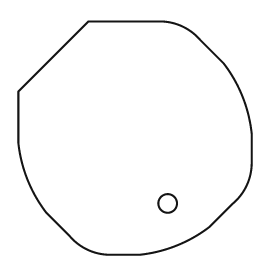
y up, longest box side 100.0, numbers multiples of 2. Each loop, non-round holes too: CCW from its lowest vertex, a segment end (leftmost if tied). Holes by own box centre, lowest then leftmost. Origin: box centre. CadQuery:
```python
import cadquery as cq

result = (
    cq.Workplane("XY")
    .moveTo(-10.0, -50.0)
    .lineTo(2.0, -50.0)
    .threePointArc((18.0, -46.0), (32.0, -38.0))
    .lineTo(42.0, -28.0)
    .threePointArc((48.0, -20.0), (50.0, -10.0))
    .lineTo(50.0, 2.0)
    .threePointArc((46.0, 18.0), (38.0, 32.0))
    .lineTo(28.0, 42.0)
    .threePointArc((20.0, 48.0), (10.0, 50.0))
    .lineTo(-20.0, 50.0)
    .lineTo(-50.0, 20.0)
    .lineTo(-50.0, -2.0)
    .threePointArc((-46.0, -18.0), (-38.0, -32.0))
    .lineTo(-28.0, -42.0)
    .threePointArc((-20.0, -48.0), (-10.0, -50.0))
    .close()
    .moveTo(14.0, -28.0)
    .circle(4.0)
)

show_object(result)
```